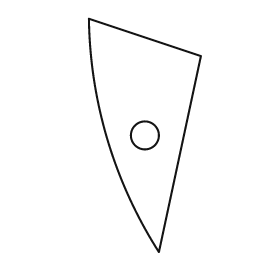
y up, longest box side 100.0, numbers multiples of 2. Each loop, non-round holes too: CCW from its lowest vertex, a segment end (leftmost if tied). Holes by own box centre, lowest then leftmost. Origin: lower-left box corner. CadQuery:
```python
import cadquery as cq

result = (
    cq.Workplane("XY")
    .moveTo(30.0, 0.0)
    .lineTo(48.0, 84.0)
    .lineTo(0.0, 100.0)
    .threePointArc((8.0, 48.0), (30.0, 0.0))
    .close()
    .moveTo(24.0, 50.0)
    .circle(6.0)
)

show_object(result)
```